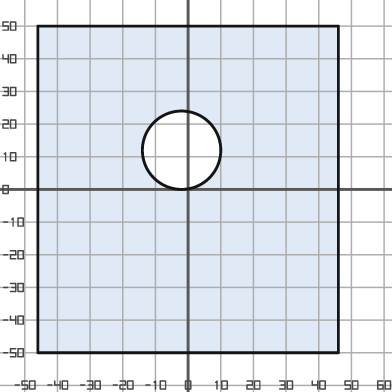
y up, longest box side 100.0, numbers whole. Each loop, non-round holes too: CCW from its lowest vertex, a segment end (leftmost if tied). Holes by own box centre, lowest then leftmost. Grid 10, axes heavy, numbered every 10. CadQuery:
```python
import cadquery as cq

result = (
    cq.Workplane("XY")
    .moveTo(-46.0, -50.0)
    .lineTo(46.0, -50.0)
    .lineTo(46.0, 50.0)
    .lineTo(-46.0, 50.0)
    .close()
    .moveTo(-2.0, 12.0)
    .circle(12.0)
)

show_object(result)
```